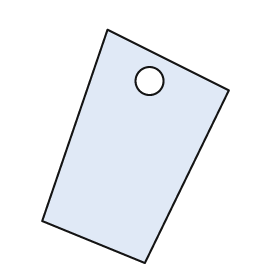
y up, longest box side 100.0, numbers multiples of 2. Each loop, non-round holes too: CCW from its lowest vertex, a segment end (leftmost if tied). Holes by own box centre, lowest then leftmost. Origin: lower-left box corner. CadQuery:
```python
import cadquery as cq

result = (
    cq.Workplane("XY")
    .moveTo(44.0, 0.0)
    .lineTo(80.0, 74.0)
    .lineTo(28.0, 100.0)
    .lineTo(0.0, 18.0)
    .close()
    .moveTo(46.0, 78.0)
    .circle(6.0)
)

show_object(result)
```